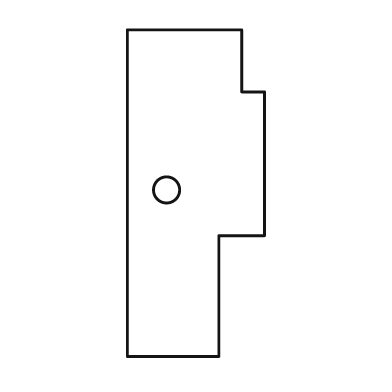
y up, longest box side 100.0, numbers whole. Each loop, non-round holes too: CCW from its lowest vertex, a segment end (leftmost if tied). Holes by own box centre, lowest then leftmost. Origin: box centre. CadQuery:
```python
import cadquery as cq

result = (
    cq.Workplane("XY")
    .moveTo(-21.0, -50.0)
    .lineTo(7.0, -50.0)
    .lineTo(7.0, -13.0)
    .lineTo(21.0, -13.0)
    .lineTo(21.0, 31.0)
    .lineTo(14.0, 31.0)
    .lineTo(14.0, 50.0)
    .lineTo(-21.0, 50.0)
    .close()
    .moveTo(-9.0, 1.0)
    .circle(4.0)
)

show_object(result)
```